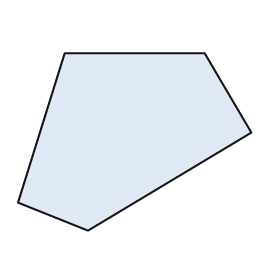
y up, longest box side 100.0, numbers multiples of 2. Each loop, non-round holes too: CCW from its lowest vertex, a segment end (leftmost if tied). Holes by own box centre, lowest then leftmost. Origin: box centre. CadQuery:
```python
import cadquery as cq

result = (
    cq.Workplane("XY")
    .moveTo(-20.0, -38.0)
    .lineTo(50.0, 4.0)
    .lineTo(30.0, 38.0)
    .lineTo(-30.0, 38.0)
    .lineTo(-50.0, -26.0)
    .close()
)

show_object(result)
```